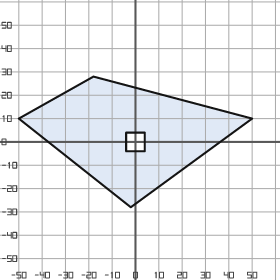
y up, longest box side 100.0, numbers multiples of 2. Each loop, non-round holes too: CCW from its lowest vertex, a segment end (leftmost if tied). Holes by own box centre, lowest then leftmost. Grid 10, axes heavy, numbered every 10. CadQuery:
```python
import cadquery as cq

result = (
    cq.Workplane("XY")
    .moveTo(-2.0, -28.0)
    .lineTo(50.0, 10.0)
    .lineTo(-18.0, 28.0)
    .lineTo(-50.0, 10.0)
    .close()
    .moveTo(-4.0, -4.0)
    .lineTo(4.0, -4.0)
    .lineTo(4.0, 4.0)
    .lineTo(-4.0, 4.0)
    .close()
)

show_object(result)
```